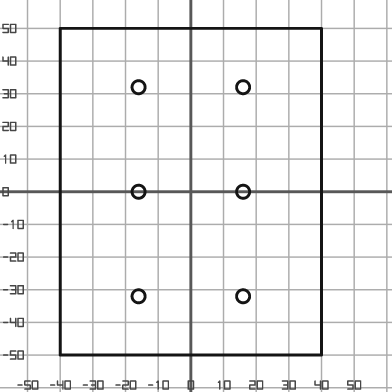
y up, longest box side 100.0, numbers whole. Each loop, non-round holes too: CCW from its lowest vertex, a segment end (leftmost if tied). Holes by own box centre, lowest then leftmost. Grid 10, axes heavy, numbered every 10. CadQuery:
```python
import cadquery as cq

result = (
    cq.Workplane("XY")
    .moveTo(-40.0, -50.0)
    .lineTo(40.0, -50.0)
    .lineTo(40.0, 50.0)
    .lineTo(-40.0, 50.0)
    .close()
    .moveTo(-16.0, -32.0)
    .circle(2.0)
    .moveTo(16.0, -32.0)
    .circle(2.0)
    .moveTo(-16.0, 0.0)
    .circle(2.0)
    .moveTo(16.0, 0.0)
    .circle(2.0)
    .moveTo(-16.0, 32.0)
    .circle(2.0)
    .moveTo(16.0, 32.0)
    .circle(2.0)
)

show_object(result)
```